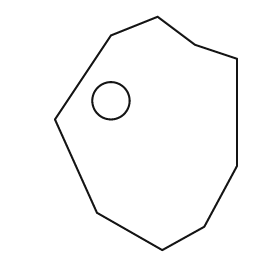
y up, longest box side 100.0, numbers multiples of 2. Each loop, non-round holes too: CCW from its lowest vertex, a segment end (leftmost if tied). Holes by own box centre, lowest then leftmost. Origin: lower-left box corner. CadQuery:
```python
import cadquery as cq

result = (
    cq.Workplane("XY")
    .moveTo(46.0, 0.0)
    .lineTo(64.0, 10.0)
    .lineTo(78.0, 36.0)
    .lineTo(78.0, 82.0)
    .lineTo(60.0, 88.0)
    .lineTo(44.0, 100.0)
    .lineTo(24.0, 92.0)
    .lineTo(0.0, 56.0)
    .lineTo(18.0, 16.0)
    .close()
    .moveTo(24.0, 64.0)
    .circle(8.0)
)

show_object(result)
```